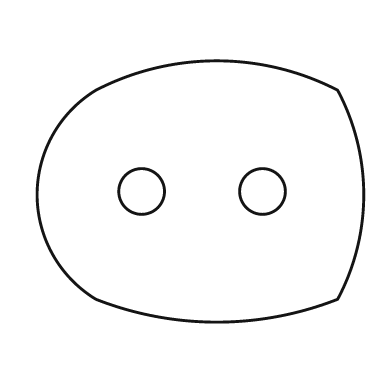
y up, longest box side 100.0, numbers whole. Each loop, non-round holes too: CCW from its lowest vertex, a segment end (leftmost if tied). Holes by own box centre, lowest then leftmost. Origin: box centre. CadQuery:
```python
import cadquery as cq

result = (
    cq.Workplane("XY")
    .moveTo(-32.0, -33.0)
    .threePointArc((5.0, -40.0), (42.0, -33.0))
    .threePointArc((50.0, -1.0), (42.0, 31.0))
    .threePointArc((5.0, 40.0), (-32.0, 31.0))
    .threePointArc((-50.0, -1.0), (-32.0, -33.0))
    .close()
    .moveTo(-18.0, 0.0)
    .circle(7.0)
    .moveTo(19.0, 0.0)
    .circle(7.0)
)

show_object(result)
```